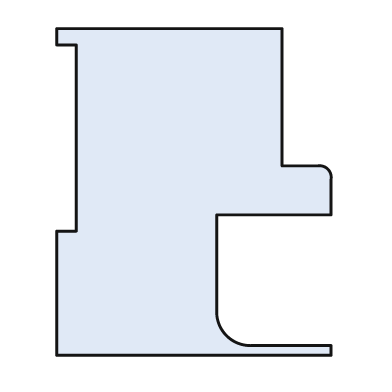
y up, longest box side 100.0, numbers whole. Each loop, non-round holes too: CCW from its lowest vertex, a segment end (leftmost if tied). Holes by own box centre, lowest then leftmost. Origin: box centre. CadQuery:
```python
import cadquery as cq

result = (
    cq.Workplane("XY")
    .moveTo(-42.0, -50.0)
    .lineTo(42.0, -50.0)
    .lineTo(42.0, -47.0)
    .lineTo(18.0, -47.0)
    .threePointArc((10.0, -44.0), (7.0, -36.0))
    .lineTo(7.0, -7.0)
    .lineTo(42.0, -7.0)
    .lineTo(42.0, 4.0)
    .threePointArc((41.0, 7.0), (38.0, 8.0))
    .lineTo(27.0, 8.0)
    .lineTo(27.0, 50.0)
    .lineTo(-42.0, 50.0)
    .lineTo(-42.0, 45.0)
    .lineTo(-36.0, 45.0)
    .lineTo(-36.0, -12.0)
    .lineTo(-42.0, -12.0)
    .close()
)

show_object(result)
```